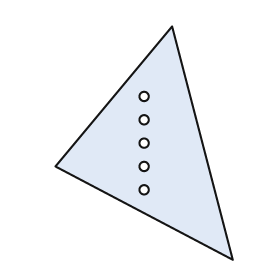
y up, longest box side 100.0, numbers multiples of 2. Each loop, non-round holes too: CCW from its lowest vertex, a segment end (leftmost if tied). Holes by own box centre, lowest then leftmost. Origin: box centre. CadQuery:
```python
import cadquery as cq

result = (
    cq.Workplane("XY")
    .moveTo(38.0, -50.0)
    .lineTo(12.0, 50.0)
    .lineTo(-38.0, -10.0)
    .close()
    .moveTo(0.0, -20.0)
    .circle(2.0)
    .moveTo(0.0, -10.0)
    .circle(2.0)
    .moveTo(0.0, 0.0)
    .circle(2.0)
    .moveTo(0.0, 10.0)
    .circle(2.0)
    .moveTo(0.0, 20.0)
    .circle(2.0)
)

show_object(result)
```